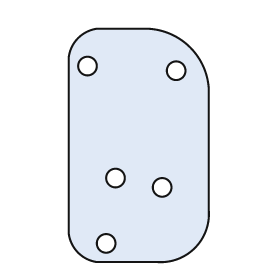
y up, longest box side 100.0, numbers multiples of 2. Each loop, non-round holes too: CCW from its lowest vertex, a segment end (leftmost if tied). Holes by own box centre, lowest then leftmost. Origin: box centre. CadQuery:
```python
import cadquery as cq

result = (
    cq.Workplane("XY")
    .moveTo(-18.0, -50.0)
    .lineTo(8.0, -50.0)
    .threePointArc((24.0, -44.0), (30.0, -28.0))
    .lineTo(30.0, 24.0)
    .threePointArc((22.0, 42.0), (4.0, 50.0))
    .lineTo(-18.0, 50.0)
    .threePointArc((-26.0, 46.0), (-30.0, 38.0))
    .lineTo(-30.0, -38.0)
    .threePointArc((-26.0, -46.0), (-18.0, -50.0))
    .close()
    .moveTo(-14.0, -42.0)
    .circle(4.0)
    .moveTo(10.0, -18.0)
    .circle(4.0)
    .moveTo(-10.0, -14.0)
    .circle(4.0)
    .moveTo(16.0, 32.0)
    .circle(4.0)
    .moveTo(-22.0, 34.0)
    .circle(4.0)
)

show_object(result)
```